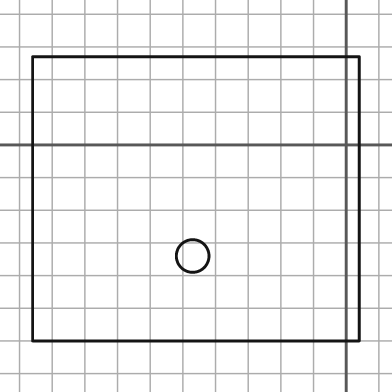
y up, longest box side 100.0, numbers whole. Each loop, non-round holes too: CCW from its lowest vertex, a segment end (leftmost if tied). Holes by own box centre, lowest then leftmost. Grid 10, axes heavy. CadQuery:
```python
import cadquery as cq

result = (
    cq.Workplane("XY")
    .moveTo(-96.0, -60.0)
    .lineTo(4.0, -60.0)
    .lineTo(4.0, 27.0)
    .lineTo(-96.0, 27.0)
    .close()
    .moveTo(-47.0, -34.0)
    .circle(5.0)
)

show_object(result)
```